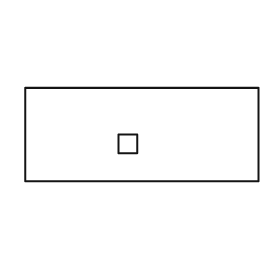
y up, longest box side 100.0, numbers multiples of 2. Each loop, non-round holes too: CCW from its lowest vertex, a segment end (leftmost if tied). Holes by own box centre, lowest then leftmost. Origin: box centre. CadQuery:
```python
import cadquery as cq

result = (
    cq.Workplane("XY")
    .moveTo(-50.0, -20.0)
    .lineTo(50.0, -20.0)
    .lineTo(50.0, 20.0)
    .lineTo(-50.0, 20.0)
    .close()
    .moveTo(-10.0, -8.0)
    .lineTo(-2.0, -8.0)
    .lineTo(-2.0, 0.0)
    .lineTo(-10.0, 0.0)
    .close()
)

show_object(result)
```